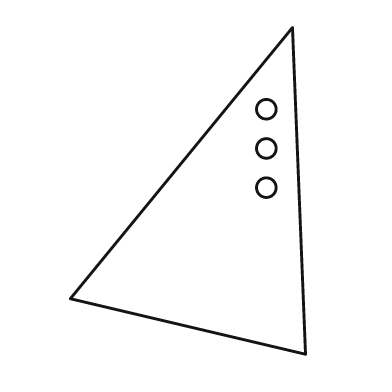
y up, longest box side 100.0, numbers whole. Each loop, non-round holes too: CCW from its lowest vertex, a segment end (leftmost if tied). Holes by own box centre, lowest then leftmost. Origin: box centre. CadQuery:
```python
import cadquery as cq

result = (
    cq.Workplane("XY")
    .moveTo(36.0, -50.0)
    .lineTo(32.0, 50.0)
    .lineTo(-36.0, -33.0)
    .close()
    .moveTo(24.0, 1.0)
    .circle(3.0)
    .moveTo(24.0, 13.0)
    .circle(3.0)
    .moveTo(24.0, 25.0)
    .circle(3.0)
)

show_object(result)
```